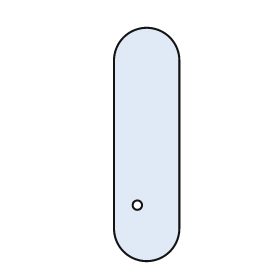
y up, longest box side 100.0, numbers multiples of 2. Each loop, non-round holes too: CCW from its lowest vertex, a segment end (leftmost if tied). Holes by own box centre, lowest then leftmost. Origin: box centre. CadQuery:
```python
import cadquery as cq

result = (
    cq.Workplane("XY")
    .moveTo(-14.0, -36.0)
    .threePointArc((0.0, -50.0), (14.0, -36.0))
    .lineTo(14.0, 36.0)
    .threePointArc((0.0, 50.0), (-14.0, 36.0))
    .close()
    .moveTo(-4.0, -26.0)
    .circle(2.0)
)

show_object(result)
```